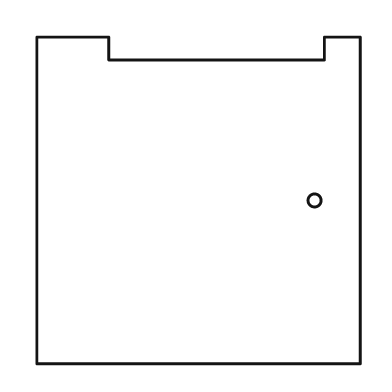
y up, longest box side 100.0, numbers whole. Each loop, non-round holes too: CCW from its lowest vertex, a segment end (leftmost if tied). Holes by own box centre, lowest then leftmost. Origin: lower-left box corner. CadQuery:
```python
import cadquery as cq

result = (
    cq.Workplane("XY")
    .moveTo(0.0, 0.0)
    .lineTo(99.0, 0.0)
    .lineTo(99.0, 100.0)
    .lineTo(88.0, 100.0)
    .lineTo(88.0, 93.0)
    .lineTo(22.0, 93.0)
    .lineTo(22.0, 100.0)
    .lineTo(0.0, 100.0)
    .close()
    .moveTo(85.0, 50.0)
    .circle(2.0)
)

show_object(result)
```